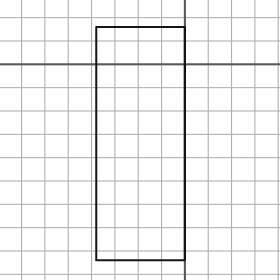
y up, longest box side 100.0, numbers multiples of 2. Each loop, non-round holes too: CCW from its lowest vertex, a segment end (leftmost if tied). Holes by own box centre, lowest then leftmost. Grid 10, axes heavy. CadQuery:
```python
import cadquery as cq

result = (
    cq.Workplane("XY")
    .moveTo(-38.0, -84.0)
    .lineTo(0.0, -84.0)
    .lineTo(0.0, 16.0)
    .lineTo(-38.0, 16.0)
    .close()
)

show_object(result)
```